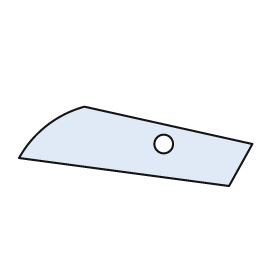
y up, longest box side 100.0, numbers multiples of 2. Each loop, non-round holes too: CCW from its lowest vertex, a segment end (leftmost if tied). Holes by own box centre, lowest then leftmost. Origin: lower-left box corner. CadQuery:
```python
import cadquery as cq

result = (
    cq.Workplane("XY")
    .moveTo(90.0, 0.0)
    .lineTo(100.0, 18.0)
    .lineTo(28.0, 34.0)
    .threePointArc((12.0, 26.0), (0.0, 12.0))
    .close()
    .moveTo(62.0, 18.0)
    .circle(4.0)
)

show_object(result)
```